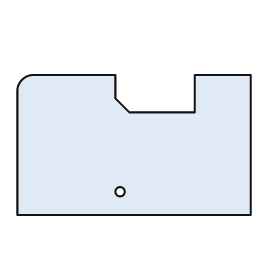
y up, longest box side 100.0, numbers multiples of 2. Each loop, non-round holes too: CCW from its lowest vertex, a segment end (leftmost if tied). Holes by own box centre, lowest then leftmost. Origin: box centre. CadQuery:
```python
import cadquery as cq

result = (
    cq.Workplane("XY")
    .moveTo(-50.0, -30.0)
    .lineTo(50.0, -30.0)
    .lineTo(50.0, 30.0)
    .lineTo(26.0, 30.0)
    .lineTo(26.0, 14.0)
    .lineTo(-2.0, 14.0)
    .lineTo(-8.0, 20.0)
    .lineTo(-8.0, 30.0)
    .lineTo(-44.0, 30.0)
    .threePointArc((-48.0, 28.0), (-50.0, 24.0))
    .close()
    .moveTo(-6.0, -20.0)
    .circle(2.0)
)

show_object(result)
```